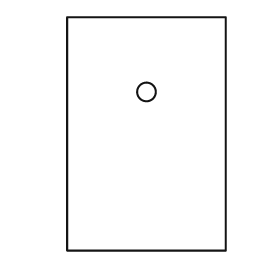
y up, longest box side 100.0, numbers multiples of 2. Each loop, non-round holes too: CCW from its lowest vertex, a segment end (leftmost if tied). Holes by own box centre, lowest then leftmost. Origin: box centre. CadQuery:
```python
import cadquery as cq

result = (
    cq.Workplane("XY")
    .moveTo(-34.0, -50.0)
    .lineTo(34.0, -50.0)
    .lineTo(34.0, 50.0)
    .lineTo(-34.0, 50.0)
    .close()
    .moveTo(0.0, 18.0)
    .circle(4.0)
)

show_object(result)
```